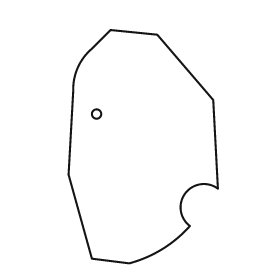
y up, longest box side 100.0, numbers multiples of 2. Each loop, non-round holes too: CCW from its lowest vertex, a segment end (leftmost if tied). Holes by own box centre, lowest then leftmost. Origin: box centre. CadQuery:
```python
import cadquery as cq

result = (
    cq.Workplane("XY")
    .moveTo(-6.0, -50.0)
    .threePointArc((8.0, -44.0), (20.0, -34.0))
    .threePointArc((18.0, -20.0), (32.0, -18.0))
    .lineTo(30.0, 20.0)
    .lineTo(6.0, 48.0)
    .lineTo(-14.0, 50.0)
    .lineTo(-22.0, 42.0)
    .threePointArc((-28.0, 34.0), (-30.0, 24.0))
    .lineTo(-32.0, -12.0)
    .lineTo(-22.0, -48.0)
    .close()
    .moveTo(-20.0, 14.0)
    .circle(2.0)
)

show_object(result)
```